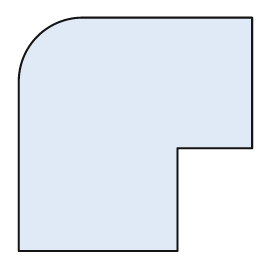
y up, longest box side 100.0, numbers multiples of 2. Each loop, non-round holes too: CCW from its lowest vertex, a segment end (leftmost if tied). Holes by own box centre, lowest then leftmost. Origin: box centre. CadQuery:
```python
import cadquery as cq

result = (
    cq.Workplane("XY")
    .moveTo(-50.0, -50.0)
    .lineTo(18.0, -50.0)
    .lineTo(18.0, -6.0)
    .lineTo(50.0, -6.0)
    .lineTo(50.0, 50.0)
    .lineTo(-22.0, 50.0)
    .threePointArc((-42.0, 42.0), (-50.0, 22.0))
    .close()
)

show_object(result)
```